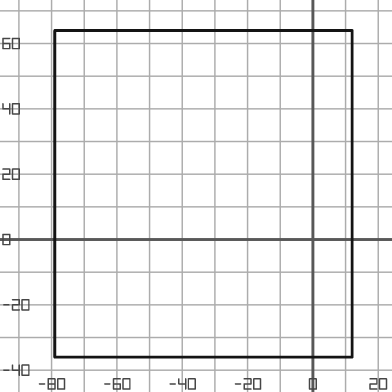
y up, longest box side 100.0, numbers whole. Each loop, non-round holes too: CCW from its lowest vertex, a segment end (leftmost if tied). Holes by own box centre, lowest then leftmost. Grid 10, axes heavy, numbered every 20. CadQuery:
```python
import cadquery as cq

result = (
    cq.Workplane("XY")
    .moveTo(-79.0, -36.0)
    .lineTo(12.0, -36.0)
    .lineTo(12.0, 64.0)
    .lineTo(-79.0, 64.0)
    .close()
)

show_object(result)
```